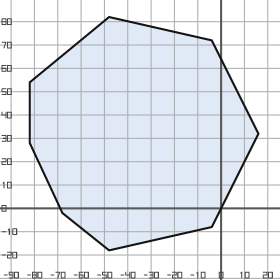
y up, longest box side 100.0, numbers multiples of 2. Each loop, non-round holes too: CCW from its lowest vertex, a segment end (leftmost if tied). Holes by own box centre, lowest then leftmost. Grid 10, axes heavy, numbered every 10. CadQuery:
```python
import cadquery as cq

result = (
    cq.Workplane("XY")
    .moveTo(-48.0, -18.0)
    .lineTo(-4.0, -8.0)
    .lineTo(16.0, 32.0)
    .lineTo(-4.0, 72.0)
    .lineTo(-48.0, 82.0)
    .lineTo(-82.0, 54.0)
    .lineTo(-82.0, 28.0)
    .lineTo(-68.0, -2.0)
    .close()
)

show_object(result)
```